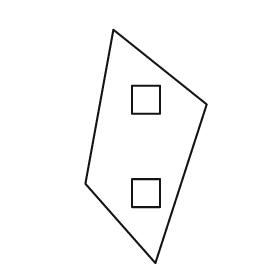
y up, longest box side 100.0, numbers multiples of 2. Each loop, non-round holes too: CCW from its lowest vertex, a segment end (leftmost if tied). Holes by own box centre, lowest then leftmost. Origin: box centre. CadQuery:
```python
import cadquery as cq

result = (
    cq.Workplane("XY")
    .moveTo(4.0, -50.0)
    .lineTo(26.0, 18.0)
    .lineTo(-14.0, 50.0)
    .lineTo(-26.0, -16.0)
    .close()
    .moveTo(-6.0, -26.0)
    .lineTo(6.0, -26.0)
    .lineTo(6.0, -14.0)
    .lineTo(-6.0, -14.0)
    .close()
    .moveTo(-6.0, 14.0)
    .lineTo(6.0, 14.0)
    .lineTo(6.0, 26.0)
    .lineTo(-6.0, 26.0)
    .close()
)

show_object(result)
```